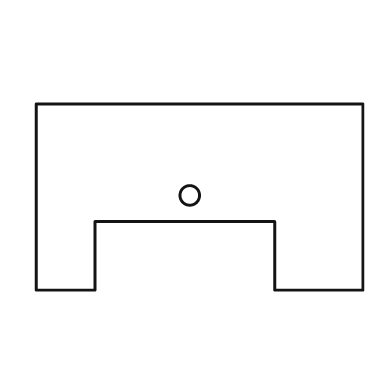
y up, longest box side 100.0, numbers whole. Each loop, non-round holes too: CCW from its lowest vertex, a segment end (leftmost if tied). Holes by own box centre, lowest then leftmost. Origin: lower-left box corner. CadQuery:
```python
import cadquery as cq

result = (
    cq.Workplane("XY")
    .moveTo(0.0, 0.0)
    .lineTo(18.0, 0.0)
    .lineTo(18.0, 21.0)
    .lineTo(73.0, 21.0)
    .lineTo(73.0, 0.0)
    .lineTo(100.0, 0.0)
    .lineTo(100.0, 57.0)
    .lineTo(0.0, 57.0)
    .close()
    .moveTo(47.0, 29.0)
    .circle(3.0)
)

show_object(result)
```